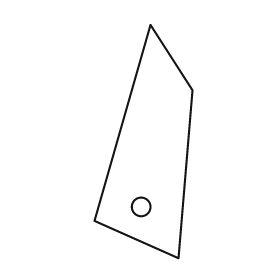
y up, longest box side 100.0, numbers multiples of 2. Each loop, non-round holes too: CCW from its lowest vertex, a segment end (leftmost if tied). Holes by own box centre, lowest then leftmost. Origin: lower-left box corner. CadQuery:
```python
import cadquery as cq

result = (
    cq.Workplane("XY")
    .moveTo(36.0, 0.0)
    .lineTo(42.0, 72.0)
    .lineTo(24.0, 100.0)
    .lineTo(0.0, 16.0)
    .close()
    .moveTo(20.0, 22.0)
    .circle(4.0)
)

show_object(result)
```